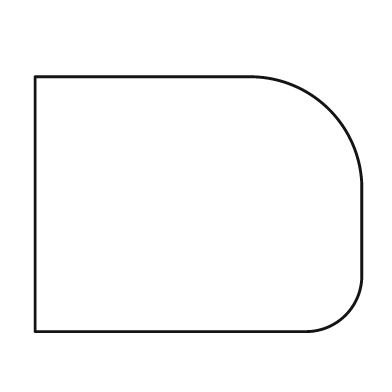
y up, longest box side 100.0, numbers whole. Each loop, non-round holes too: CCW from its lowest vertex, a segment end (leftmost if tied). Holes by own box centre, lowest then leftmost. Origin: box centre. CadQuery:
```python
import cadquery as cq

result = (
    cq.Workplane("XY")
    .moveTo(-50.0, -39.0)
    .lineTo(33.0, -39.0)
    .threePointArc((45.0, -34.0), (50.0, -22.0))
    .lineTo(50.0, 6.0)
    .threePointArc((40.0, 29.0), (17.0, 39.0))
    .lineTo(-50.0, 39.0)
    .close()
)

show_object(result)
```